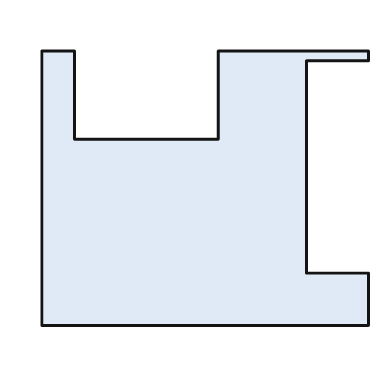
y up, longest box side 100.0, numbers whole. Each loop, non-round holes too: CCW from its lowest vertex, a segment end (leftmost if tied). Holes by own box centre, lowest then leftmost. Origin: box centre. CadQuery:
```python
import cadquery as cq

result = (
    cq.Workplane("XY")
    .moveTo(-50.0, -42.0)
    .lineTo(50.0, -42.0)
    .lineTo(50.0, -26.0)
    .lineTo(31.0, -26.0)
    .lineTo(31.0, 39.0)
    .lineTo(50.0, 39.0)
    .lineTo(50.0, 42.0)
    .lineTo(4.0, 42.0)
    .lineTo(4.0, 15.0)
    .lineTo(-40.0, 15.0)
    .lineTo(-40.0, 42.0)
    .lineTo(-50.0, 42.0)
    .close()
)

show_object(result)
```